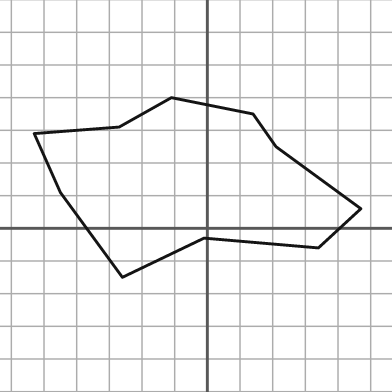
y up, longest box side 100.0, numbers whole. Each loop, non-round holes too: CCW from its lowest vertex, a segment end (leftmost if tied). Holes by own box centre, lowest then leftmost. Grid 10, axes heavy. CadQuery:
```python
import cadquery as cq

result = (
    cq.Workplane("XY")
    .moveTo(-26.0, -15.0)
    .lineTo(-1.0, -3.0)
    .lineTo(34.0, -6.0)
    .lineTo(47.0, 6.0)
    .lineTo(21.0, 25.0)
    .lineTo(14.0, 35.0)
    .lineTo(-11.0, 40.0)
    .lineTo(-27.0, 31.0)
    .lineTo(-53.0, 29.0)
    .lineTo(-45.0, 11.0)
    .close()
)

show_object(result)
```